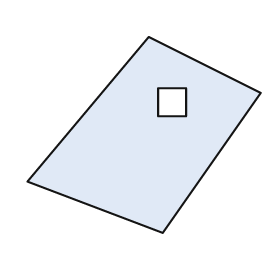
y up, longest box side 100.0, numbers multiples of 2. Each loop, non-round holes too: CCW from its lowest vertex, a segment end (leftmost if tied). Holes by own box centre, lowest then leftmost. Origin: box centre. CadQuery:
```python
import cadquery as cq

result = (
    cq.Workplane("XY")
    .moveTo(8.0, -42.0)
    .lineTo(50.0, 18.0)
    .lineTo(2.0, 42.0)
    .lineTo(-50.0, -20.0)
    .close()
    .moveTo(6.0, 8.0)
    .lineTo(18.0, 8.0)
    .lineTo(18.0, 20.0)
    .lineTo(6.0, 20.0)
    .close()
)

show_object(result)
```